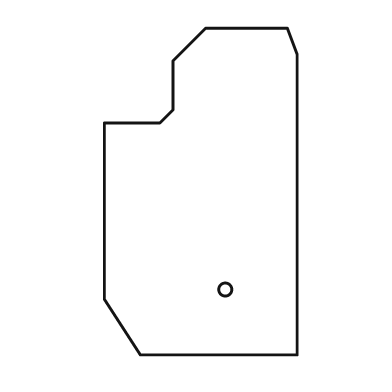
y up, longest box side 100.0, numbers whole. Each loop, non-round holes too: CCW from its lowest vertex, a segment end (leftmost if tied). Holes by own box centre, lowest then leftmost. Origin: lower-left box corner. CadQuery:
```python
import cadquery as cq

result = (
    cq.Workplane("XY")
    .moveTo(11.0, 0.0)
    .lineTo(59.0, 0.0)
    .lineTo(59.0, 92.0)
    .lineTo(56.0, 100.0)
    .lineTo(31.0, 100.0)
    .lineTo(21.0, 90.0)
    .lineTo(21.0, 75.0)
    .lineTo(17.0, 71.0)
    .lineTo(0.0, 71.0)
    .lineTo(0.0, 17.0)
    .close()
    .moveTo(37.0, 20.0)
    .circle(2.0)
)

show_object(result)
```